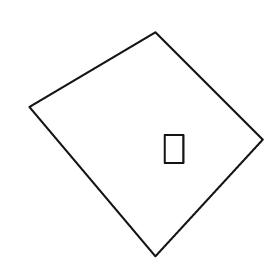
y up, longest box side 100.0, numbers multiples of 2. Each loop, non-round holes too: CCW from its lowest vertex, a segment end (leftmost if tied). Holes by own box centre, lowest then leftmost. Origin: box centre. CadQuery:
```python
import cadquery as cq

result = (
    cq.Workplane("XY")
    .moveTo(4.0, -48.0)
    .lineTo(50.0, 2.0)
    .lineTo(4.0, 48.0)
    .lineTo(-50.0, 16.0)
    .close()
    .moveTo(8.0, -8.0)
    .lineTo(16.0, -8.0)
    .lineTo(16.0, 4.0)
    .lineTo(8.0, 4.0)
    .close()
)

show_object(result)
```